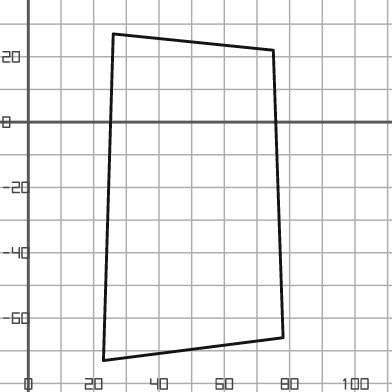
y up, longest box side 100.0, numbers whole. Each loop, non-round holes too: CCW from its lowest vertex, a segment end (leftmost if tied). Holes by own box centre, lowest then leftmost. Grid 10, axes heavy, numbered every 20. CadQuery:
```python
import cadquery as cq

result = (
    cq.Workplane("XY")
    .moveTo(23.0, -73.0)
    .lineTo(78.0, -66.0)
    .lineTo(75.0, 22.0)
    .lineTo(26.0, 27.0)
    .close()
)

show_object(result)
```